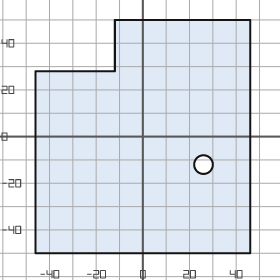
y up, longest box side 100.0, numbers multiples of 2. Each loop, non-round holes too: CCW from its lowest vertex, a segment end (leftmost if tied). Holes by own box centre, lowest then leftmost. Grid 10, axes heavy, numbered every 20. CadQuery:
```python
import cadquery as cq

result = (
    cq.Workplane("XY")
    .moveTo(-46.0, -50.0)
    .lineTo(46.0, -50.0)
    .lineTo(46.0, 50.0)
    .lineTo(-12.0, 50.0)
    .lineTo(-12.0, 28.0)
    .lineTo(-46.0, 28.0)
    .close()
    .moveTo(26.0, -12.0)
    .circle(4.0)
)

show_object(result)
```